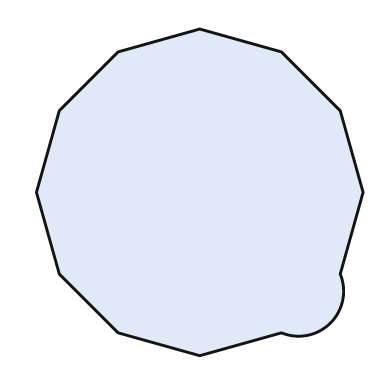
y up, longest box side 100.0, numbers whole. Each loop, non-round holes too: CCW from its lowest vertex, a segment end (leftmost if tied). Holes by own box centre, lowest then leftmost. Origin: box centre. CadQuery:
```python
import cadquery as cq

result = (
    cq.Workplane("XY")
    .moveTo(0.0, -50.0)
    .lineTo(25.0, -43.0)
    .threePointArc((40.0, -40.0), (43.0, -25.0))
    .lineTo(50.0, 0.0)
    .lineTo(43.0, 25.0)
    .lineTo(25.0, 43.0)
    .lineTo(0.0, 50.0)
    .lineTo(-25.0, 43.0)
    .lineTo(-43.0, 25.0)
    .lineTo(-50.0, 0.0)
    .lineTo(-43.0, -25.0)
    .lineTo(-25.0, -43.0)
    .close()
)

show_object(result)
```